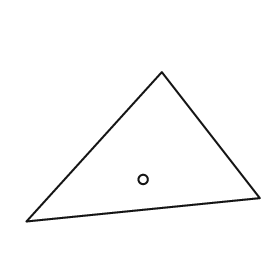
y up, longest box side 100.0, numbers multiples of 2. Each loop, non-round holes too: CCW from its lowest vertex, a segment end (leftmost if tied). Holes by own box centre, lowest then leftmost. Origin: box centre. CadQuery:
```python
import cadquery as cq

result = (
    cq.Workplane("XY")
    .moveTo(-50.0, -32.0)
    .lineTo(50.0, -22.0)
    .lineTo(8.0, 32.0)
    .close()
    .moveTo(0.0, -14.0)
    .circle(2.0)
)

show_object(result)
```